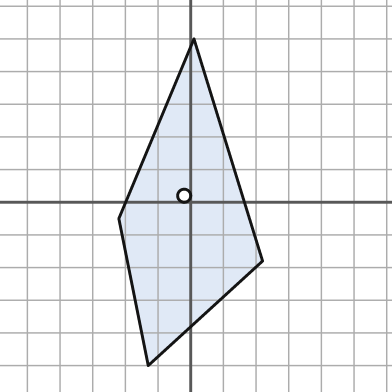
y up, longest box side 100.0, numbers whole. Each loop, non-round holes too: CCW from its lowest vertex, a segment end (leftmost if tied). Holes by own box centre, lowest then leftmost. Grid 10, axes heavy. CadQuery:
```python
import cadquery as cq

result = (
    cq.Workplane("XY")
    .moveTo(-13.0, -50.0)
    .lineTo(22.0, -18.0)
    .lineTo(1.0, 50.0)
    .lineTo(-22.0, -5.0)
    .close()
    .moveTo(-2.0, 2.0)
    .circle(2.0)
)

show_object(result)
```